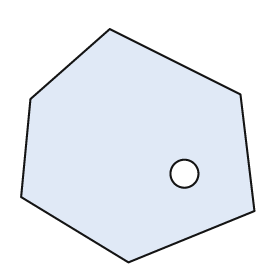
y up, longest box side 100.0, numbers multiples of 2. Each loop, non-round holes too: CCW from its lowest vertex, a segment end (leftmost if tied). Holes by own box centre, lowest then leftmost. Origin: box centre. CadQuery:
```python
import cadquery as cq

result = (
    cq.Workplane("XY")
    .moveTo(-4.0, -50.0)
    .lineTo(50.0, -28.0)
    .lineTo(44.0, 22.0)
    .lineTo(-12.0, 50.0)
    .lineTo(-46.0, 20.0)
    .lineTo(-50.0, -22.0)
    .close()
    .moveTo(20.0, -12.0)
    .circle(6.0)
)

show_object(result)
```